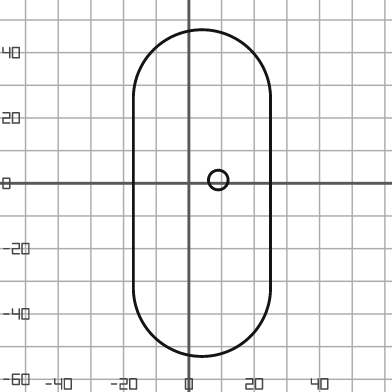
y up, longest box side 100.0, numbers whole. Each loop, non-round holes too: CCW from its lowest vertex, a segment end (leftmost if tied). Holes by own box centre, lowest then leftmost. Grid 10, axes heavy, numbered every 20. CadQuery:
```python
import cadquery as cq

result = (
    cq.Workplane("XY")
    .moveTo(-17.0, -32.0)
    .threePointArc((4.0, -53.0), (25.0, -32.0))
    .lineTo(25.0, 26.0)
    .threePointArc((4.0, 47.0), (-17.0, 26.0))
    .close()
    .moveTo(9.0, 1.0)
    .circle(3.0)
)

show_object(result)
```